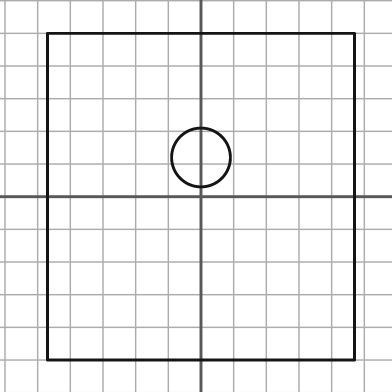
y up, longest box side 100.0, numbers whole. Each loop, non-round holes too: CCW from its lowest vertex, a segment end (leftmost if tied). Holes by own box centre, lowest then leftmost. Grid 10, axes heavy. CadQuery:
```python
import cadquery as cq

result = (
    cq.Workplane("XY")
    .moveTo(-47.0, -50.0)
    .lineTo(47.0, -50.0)
    .lineTo(47.0, 50.0)
    .lineTo(-47.0, 50.0)
    .close()
    .moveTo(0.0, 12.0)
    .circle(9.0)
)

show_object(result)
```